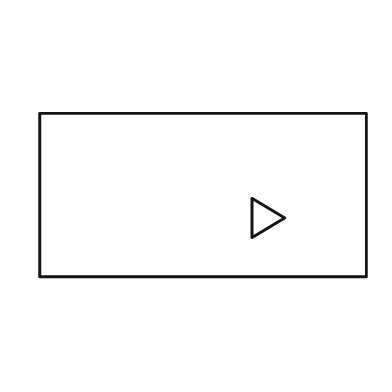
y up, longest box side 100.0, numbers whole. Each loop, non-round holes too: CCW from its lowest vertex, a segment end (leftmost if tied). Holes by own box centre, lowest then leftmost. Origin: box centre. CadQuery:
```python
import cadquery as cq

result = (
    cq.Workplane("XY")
    .moveTo(-50.0, -25.0)
    .lineTo(50.0, -25.0)
    .lineTo(50.0, 25.0)
    .lineTo(-50.0, 25.0)
    .close()
    .moveTo(15.0, -13.0)
    .lineTo(25.0, -7.0)
    .lineTo(15.0, -1.0)
    .close()
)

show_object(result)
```